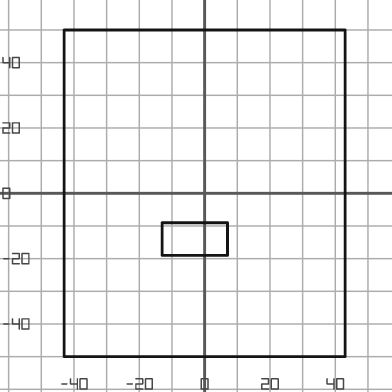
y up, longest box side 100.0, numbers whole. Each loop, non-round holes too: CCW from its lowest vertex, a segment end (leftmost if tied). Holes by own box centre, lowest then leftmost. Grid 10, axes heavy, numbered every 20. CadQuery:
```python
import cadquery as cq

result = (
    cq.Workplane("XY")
    .moveTo(-43.0, -50.0)
    .lineTo(43.0, -50.0)
    .lineTo(43.0, 50.0)
    .lineTo(-43.0, 50.0)
    .close()
    .moveTo(-13.0, -19.0)
    .lineTo(7.0, -19.0)
    .lineTo(7.0, -9.0)
    .lineTo(-13.0, -9.0)
    .close()
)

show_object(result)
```